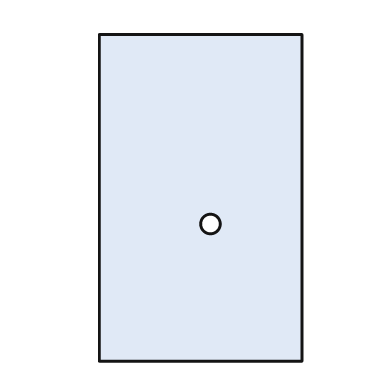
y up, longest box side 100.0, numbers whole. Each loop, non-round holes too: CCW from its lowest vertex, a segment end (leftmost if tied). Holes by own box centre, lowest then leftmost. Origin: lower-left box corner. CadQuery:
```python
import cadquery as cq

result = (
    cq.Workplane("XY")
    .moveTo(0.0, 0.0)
    .lineTo(62.0, 0.0)
    .lineTo(62.0, 100.0)
    .lineTo(0.0, 100.0)
    .close()
    .moveTo(34.0, 42.0)
    .circle(3.0)
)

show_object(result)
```